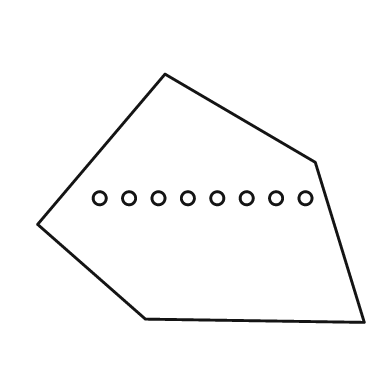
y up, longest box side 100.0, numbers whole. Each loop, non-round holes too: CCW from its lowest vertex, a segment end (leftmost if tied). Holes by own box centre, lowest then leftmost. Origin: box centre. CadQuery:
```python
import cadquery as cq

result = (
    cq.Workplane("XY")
    .moveTo(50.0, -38.0)
    .lineTo(35.0, 11.0)
    .lineTo(-11.0, 38.0)
    .lineTo(-50.0, -8.0)
    .lineTo(-17.0, -37.0)
    .close()
    .moveTo(-31.0, 0.0)
    .circle(2.0)
    .moveTo(-22.0, 0.0)
    .circle(2.0)
    .moveTo(-13.0, 0.0)
    .circle(2.0)
    .moveTo(-4.0, 0.0)
    .circle(2.0)
    .moveTo(5.0, 0.0)
    .circle(2.0)
    .moveTo(14.0, 0.0)
    .circle(2.0)
    .moveTo(23.0, 0.0)
    .circle(2.0)
    .moveTo(32.0, 0.0)
    .circle(2.0)
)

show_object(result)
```